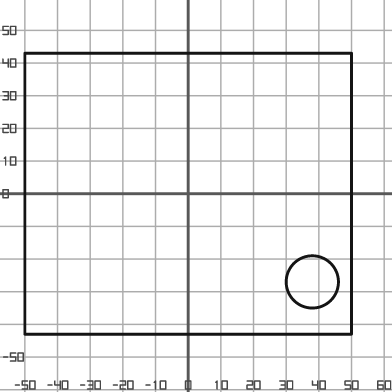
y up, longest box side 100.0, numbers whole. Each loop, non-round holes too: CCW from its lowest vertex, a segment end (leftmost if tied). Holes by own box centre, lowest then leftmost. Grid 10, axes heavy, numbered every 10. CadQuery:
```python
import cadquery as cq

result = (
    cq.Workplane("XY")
    .moveTo(-50.0, -43.0)
    .lineTo(50.0, -43.0)
    .lineTo(50.0, 43.0)
    .lineTo(-50.0, 43.0)
    .close()
    .moveTo(38.0, -27.0)
    .circle(8.0)
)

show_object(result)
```